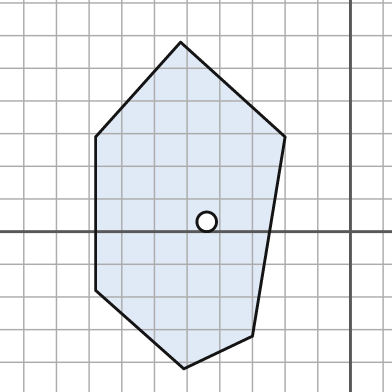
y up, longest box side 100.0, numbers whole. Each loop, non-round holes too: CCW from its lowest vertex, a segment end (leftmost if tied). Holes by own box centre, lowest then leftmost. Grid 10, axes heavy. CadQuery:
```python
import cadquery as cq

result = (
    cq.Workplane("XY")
    .moveTo(-51.0, -42.0)
    .lineTo(-30.0, -32.0)
    .lineTo(-20.0, 29.0)
    .lineTo(-52.0, 58.0)
    .lineTo(-78.0, 29.0)
    .lineTo(-78.0, -18.0)
    .close()
    .moveTo(-44.0, 3.0)
    .circle(3.0)
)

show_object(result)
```